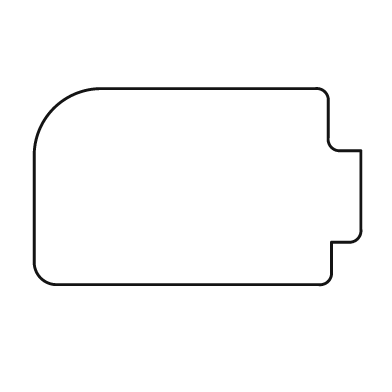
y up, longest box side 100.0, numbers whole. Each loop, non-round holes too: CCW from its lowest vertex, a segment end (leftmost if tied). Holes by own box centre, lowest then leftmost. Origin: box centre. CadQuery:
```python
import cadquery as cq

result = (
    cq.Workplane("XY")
    .moveTo(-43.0, -30.0)
    .lineTo(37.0, -30.0)
    .threePointArc((40.0, -29.0), (41.0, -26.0))
    .lineTo(41.0, -17.0)
    .lineTo(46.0, -17.0)
    .threePointArc((49.0, -16.0), (50.0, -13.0))
    .lineTo(50.0, 11.0)
    .lineTo(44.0, 11.0)
    .threePointArc((41.0, 12.0), (40.0, 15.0))
    .lineTo(40.0, 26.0)
    .threePointArc((39.0, 29.0), (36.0, 30.0))
    .lineTo(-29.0, 30.0)
    .threePointArc((-44.0, 24.0), (-50.0, 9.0))
    .lineTo(-50.0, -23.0)
    .threePointArc((-48.0, -28.0), (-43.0, -30.0))
    .close()
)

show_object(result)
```